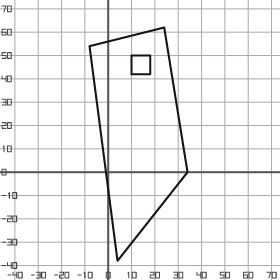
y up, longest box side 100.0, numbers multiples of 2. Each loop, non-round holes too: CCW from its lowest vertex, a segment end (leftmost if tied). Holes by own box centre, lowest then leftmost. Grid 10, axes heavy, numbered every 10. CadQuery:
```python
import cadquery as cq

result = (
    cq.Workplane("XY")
    .moveTo(4.0, -38.0)
    .lineTo(34.0, 0.0)
    .lineTo(24.0, 62.0)
    .lineTo(-8.0, 54.0)
    .close()
    .moveTo(10.0, 42.0)
    .lineTo(18.0, 42.0)
    .lineTo(18.0, 50.0)
    .lineTo(10.0, 50.0)
    .close()
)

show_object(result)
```